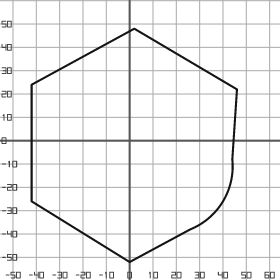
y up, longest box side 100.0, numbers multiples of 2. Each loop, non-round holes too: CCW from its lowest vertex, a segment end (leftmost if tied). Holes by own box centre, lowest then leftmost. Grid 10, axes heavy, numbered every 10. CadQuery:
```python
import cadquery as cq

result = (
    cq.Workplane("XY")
    .moveTo(0.0, -52.0)
    .lineTo(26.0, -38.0)
    .threePointArc((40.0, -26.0), (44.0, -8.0))
    .lineTo(46.0, 22.0)
    .lineTo(2.0, 48.0)
    .lineTo(-42.0, 24.0)
    .lineTo(-42.0, -26.0)
    .close()
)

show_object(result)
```